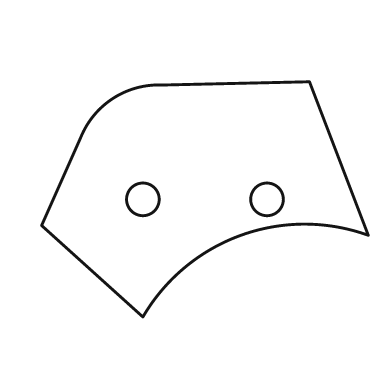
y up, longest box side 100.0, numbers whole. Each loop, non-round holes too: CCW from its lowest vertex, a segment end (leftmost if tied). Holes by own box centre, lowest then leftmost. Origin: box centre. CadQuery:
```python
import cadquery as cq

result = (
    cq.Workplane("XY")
    .moveTo(-19.0, -36.0)
    .threePointArc((11.0, -11.0), (50.0, -11.0))
    .lineTo(32.0, 36.0)
    .lineTo(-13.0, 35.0)
    .threePointArc((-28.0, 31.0), (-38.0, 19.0))
    .lineTo(-50.0, -8.0)
    .close()
    .moveTo(-19.0, 0.0)
    .circle(5.0)
    .moveTo(19.0, 0.0)
    .circle(5.0)
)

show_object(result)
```